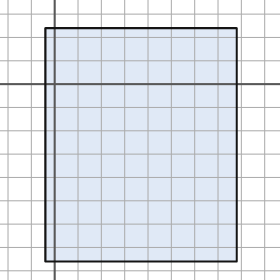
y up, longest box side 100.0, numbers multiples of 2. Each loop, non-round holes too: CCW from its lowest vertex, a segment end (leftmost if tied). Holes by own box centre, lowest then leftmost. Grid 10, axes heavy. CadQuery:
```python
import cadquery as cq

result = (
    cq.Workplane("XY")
    .moveTo(-4.0, -76.0)
    .lineTo(78.0, -76.0)
    .lineTo(78.0, 24.0)
    .lineTo(-4.0, 24.0)
    .close()
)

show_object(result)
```